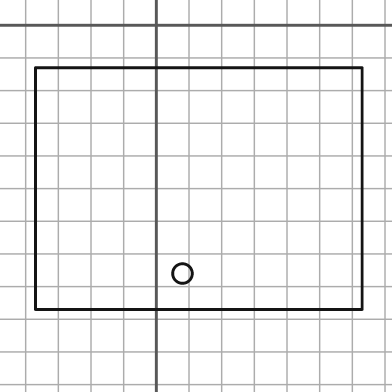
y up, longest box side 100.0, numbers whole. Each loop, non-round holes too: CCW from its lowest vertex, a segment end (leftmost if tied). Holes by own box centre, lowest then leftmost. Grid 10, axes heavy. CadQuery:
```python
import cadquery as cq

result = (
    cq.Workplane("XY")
    .moveTo(-37.0, -87.0)
    .lineTo(63.0, -87.0)
    .lineTo(63.0, -13.0)
    .lineTo(-37.0, -13.0)
    .close()
    .moveTo(8.0, -76.0)
    .circle(3.0)
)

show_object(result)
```